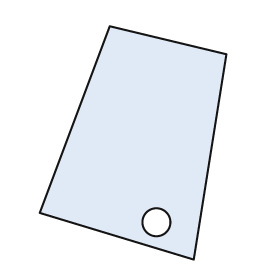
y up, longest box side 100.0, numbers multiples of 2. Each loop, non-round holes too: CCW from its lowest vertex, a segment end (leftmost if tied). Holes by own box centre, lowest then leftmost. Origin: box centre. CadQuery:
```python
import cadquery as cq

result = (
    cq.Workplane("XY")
    .moveTo(26.0, -50.0)
    .lineTo(40.0, 38.0)
    .lineTo(-10.0, 50.0)
    .lineTo(-40.0, -30.0)
    .close()
    .moveTo(10.0, -34.0)
    .circle(6.0)
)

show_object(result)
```